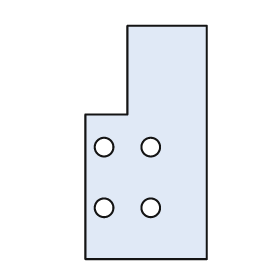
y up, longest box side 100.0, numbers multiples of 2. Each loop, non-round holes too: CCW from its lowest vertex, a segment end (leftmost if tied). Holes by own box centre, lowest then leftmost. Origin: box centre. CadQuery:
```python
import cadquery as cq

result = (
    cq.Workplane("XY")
    .moveTo(-26.0, -50.0)
    .lineTo(26.0, -50.0)
    .lineTo(26.0, 50.0)
    .lineTo(-8.0, 50.0)
    .lineTo(-8.0, 12.0)
    .lineTo(-26.0, 12.0)
    .close()
    .moveTo(-18.0, -28.0)
    .circle(4.0)
    .moveTo(2.0, -28.0)
    .circle(4.0)
    .moveTo(-18.0, -2.0)
    .circle(4.0)
    .moveTo(2.0, -2.0)
    .circle(4.0)
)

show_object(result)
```